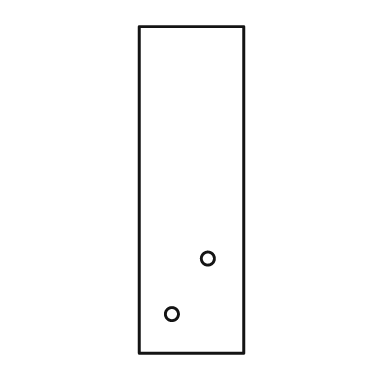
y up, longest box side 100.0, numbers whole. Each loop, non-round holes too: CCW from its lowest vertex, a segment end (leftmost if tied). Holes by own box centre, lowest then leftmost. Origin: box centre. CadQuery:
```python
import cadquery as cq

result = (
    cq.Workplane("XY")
    .moveTo(-16.0, -50.0)
    .lineTo(16.0, -50.0)
    .lineTo(16.0, 50.0)
    .lineTo(-16.0, 50.0)
    .close()
    .moveTo(-6.0, -38.0)
    .circle(2.0)
    .moveTo(5.0, -21.0)
    .circle(2.0)
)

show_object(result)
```